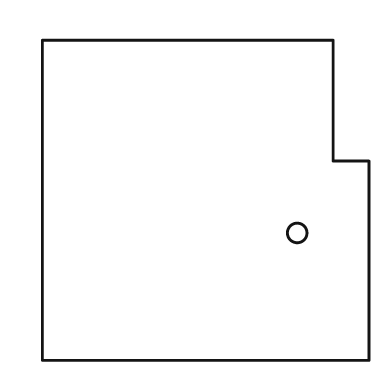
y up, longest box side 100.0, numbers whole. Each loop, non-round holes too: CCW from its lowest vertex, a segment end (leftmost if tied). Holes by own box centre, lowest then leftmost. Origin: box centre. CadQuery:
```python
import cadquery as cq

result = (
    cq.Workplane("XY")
    .moveTo(-50.0, -49.0)
    .lineTo(50.0, -49.0)
    .lineTo(50.0, 12.0)
    .lineTo(39.0, 12.0)
    .lineTo(39.0, 49.0)
    .lineTo(-50.0, 49.0)
    .close()
    .moveTo(28.0, -10.0)
    .circle(3.0)
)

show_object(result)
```